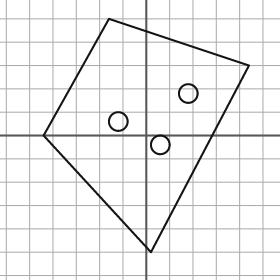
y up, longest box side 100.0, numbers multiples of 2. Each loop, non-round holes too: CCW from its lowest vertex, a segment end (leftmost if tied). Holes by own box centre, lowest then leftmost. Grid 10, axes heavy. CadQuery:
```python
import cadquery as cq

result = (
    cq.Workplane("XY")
    .moveTo(2.0, -50.0)
    .lineTo(44.0, 30.0)
    .lineTo(-16.0, 50.0)
    .lineTo(-44.0, 0.0)
    .close()
    .moveTo(6.0, -4.0)
    .circle(4.0)
    .moveTo(-12.0, 6.0)
    .circle(4.0)
    .moveTo(18.0, 18.0)
    .circle(4.0)
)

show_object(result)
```